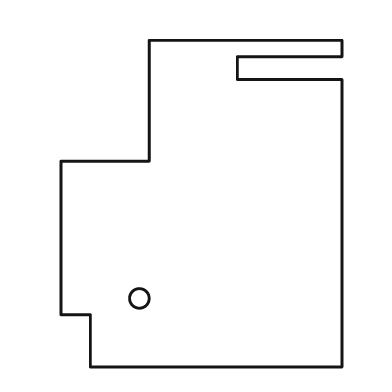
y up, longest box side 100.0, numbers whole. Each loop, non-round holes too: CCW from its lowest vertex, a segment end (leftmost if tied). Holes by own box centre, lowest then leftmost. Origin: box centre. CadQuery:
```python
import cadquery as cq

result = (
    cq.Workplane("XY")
    .moveTo(-34.0, -50.0)
    .lineTo(43.0, -50.0)
    .lineTo(43.0, 38.0)
    .lineTo(11.0, 38.0)
    .lineTo(11.0, 45.0)
    .lineTo(43.0, 45.0)
    .lineTo(43.0, 50.0)
    .lineTo(-16.0, 50.0)
    .lineTo(-16.0, 13.0)
    .lineTo(-43.0, 13.0)
    .lineTo(-43.0, -34.0)
    .lineTo(-34.0, -34.0)
    .close()
    .moveTo(-19.0, -29.0)
    .circle(3.0)
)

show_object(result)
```